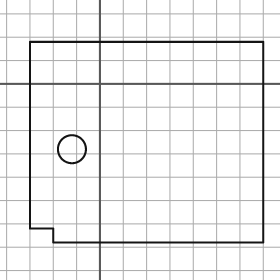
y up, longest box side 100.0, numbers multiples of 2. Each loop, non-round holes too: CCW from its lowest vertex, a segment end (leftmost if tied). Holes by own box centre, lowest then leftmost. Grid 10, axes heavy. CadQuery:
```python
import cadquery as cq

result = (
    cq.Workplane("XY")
    .moveTo(-20.0, -68.0)
    .lineTo(70.0, -68.0)
    .lineTo(70.0, 18.0)
    .lineTo(-30.0, 18.0)
    .lineTo(-30.0, -62.0)
    .lineTo(-20.0, -62.0)
    .close()
    .moveTo(-12.0, -28.0)
    .circle(6.0)
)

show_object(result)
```